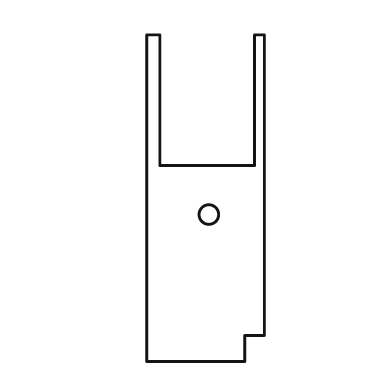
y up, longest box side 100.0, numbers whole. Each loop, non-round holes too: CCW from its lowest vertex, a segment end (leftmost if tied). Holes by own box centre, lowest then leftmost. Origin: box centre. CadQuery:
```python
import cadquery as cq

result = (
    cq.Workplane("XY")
    .moveTo(-18.0, -50.0)
    .lineTo(12.0, -50.0)
    .lineTo(12.0, -42.0)
    .lineTo(18.0, -42.0)
    .lineTo(18.0, 50.0)
    .lineTo(15.0, 50.0)
    .lineTo(15.0, 10.0)
    .lineTo(-14.0, 10.0)
    .lineTo(-14.0, 50.0)
    .lineTo(-18.0, 50.0)
    .close()
    .moveTo(1.0, -5.0)
    .circle(3.0)
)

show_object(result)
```